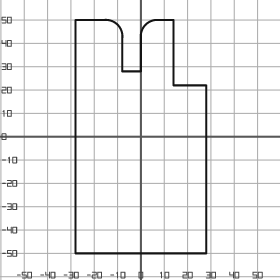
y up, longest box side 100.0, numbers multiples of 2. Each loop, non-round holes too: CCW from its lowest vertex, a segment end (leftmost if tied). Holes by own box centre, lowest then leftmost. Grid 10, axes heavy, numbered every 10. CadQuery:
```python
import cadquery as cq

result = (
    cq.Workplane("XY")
    .moveTo(-28.0, -50.0)
    .lineTo(28.0, -50.0)
    .lineTo(28.0, 22.0)
    .lineTo(14.0, 22.0)
    .lineTo(14.0, 50.0)
    .lineTo(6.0, 50.0)
    .threePointArc((2.0, 48.0), (0.0, 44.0))
    .lineTo(0.0, 28.0)
    .lineTo(-8.0, 28.0)
    .lineTo(-8.0, 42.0)
    .threePointArc((-10.0, 48.0), (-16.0, 50.0))
    .lineTo(-28.0, 50.0)
    .close()
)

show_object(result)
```